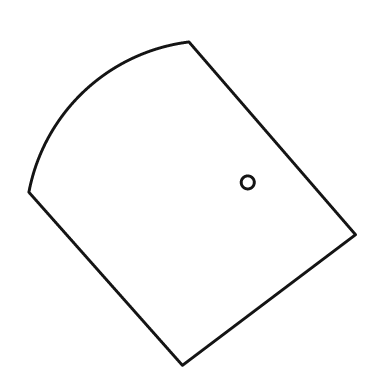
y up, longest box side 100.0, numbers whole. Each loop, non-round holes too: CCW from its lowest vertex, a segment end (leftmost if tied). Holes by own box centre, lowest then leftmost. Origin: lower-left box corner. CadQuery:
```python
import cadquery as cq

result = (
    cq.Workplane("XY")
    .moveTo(47.0, 0.0)
    .lineTo(100.0, 40.0)
    .lineTo(49.0, 99.0)
    .threePointArc((17.0, 84.0), (0.0, 53.0))
    .close()
    .moveTo(67.0, 56.0)
    .circle(2.0)
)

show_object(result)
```